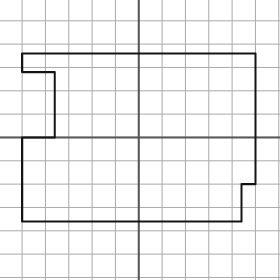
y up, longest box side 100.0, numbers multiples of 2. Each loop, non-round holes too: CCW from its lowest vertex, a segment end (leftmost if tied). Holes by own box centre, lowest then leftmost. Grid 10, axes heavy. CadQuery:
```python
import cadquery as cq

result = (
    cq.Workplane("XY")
    .moveTo(-50.0, -36.0)
    .lineTo(44.0, -36.0)
    .lineTo(44.0, -20.0)
    .lineTo(50.0, -20.0)
    .lineTo(50.0, 36.0)
    .lineTo(-50.0, 36.0)
    .lineTo(-50.0, 28.0)
    .lineTo(-36.0, 28.0)
    .lineTo(-36.0, 0.0)
    .lineTo(-50.0, 0.0)
    .close()
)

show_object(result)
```